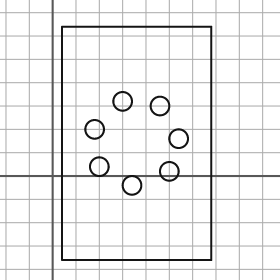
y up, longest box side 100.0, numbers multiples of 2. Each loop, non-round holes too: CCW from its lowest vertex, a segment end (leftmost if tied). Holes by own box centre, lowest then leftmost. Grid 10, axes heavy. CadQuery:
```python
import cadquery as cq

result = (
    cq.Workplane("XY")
    .moveTo(4.0, -36.0)
    .lineTo(68.0, -36.0)
    .lineTo(68.0, 64.0)
    .lineTo(4.0, 64.0)
    .close()
    .moveTo(34.0, -4.0)
    .circle(4.0)
    .moveTo(50.0, 2.0)
    .circle(4.0)
    .moveTo(20.0, 4.0)
    .circle(4.0)
    .moveTo(54.0, 16.0)
    .circle(4.0)
    .moveTo(18.0, 20.0)
    .circle(4.0)
    .moveTo(46.0, 30.0)
    .circle(4.0)
    .moveTo(30.0, 32.0)
    .circle(4.0)
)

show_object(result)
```